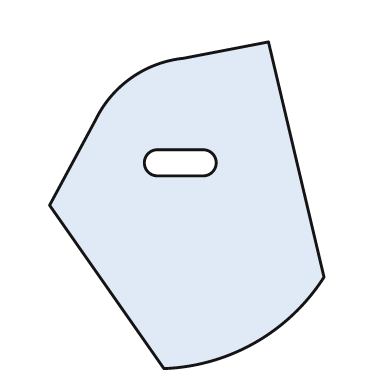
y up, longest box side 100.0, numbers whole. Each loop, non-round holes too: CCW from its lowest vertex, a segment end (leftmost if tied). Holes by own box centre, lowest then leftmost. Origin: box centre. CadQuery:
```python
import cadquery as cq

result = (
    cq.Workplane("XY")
    .moveTo(-7.0, -50.0)
    .threePointArc((21.0, -42.0), (42.0, -22.0))
    .lineTo(25.0, 50.0)
    .lineTo(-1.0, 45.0)
    .threePointArc((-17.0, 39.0), (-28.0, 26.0))
    .lineTo(-42.0, 0.0)
    .close()
    .moveTo(-9.0, 9.0)
    .lineTo(5.0, 9.0)
    .threePointArc((9.0, 13.0), (5.0, 17.0))
    .lineTo(-9.0, 17.0)
    .threePointArc((-13.0, 13.0), (-9.0, 9.0))
    .close()
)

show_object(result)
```